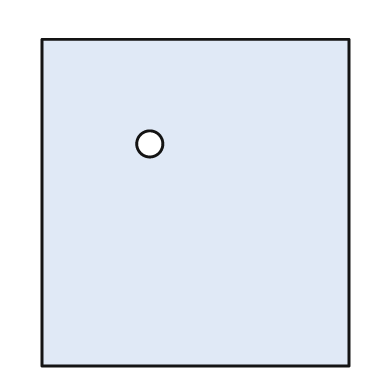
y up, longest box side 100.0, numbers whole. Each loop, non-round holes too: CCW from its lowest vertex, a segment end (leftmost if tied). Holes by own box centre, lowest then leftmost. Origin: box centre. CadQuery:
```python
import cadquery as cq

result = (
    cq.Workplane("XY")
    .moveTo(-47.0, -50.0)
    .lineTo(47.0, -50.0)
    .lineTo(47.0, 50.0)
    .lineTo(-47.0, 50.0)
    .close()
    .moveTo(-14.0, 18.0)
    .circle(4.0)
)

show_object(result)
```